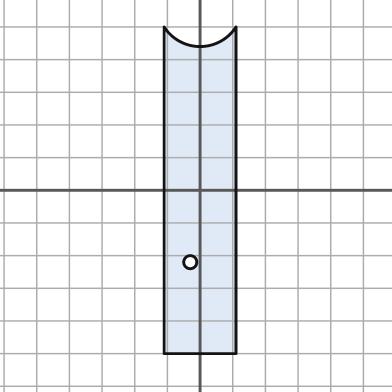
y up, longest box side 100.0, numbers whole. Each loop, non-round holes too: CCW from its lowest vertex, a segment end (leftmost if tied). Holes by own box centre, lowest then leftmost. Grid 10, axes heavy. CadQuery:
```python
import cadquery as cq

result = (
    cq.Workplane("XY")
    .moveTo(-11.0, -50.0)
    .lineTo(11.0, -50.0)
    .lineTo(11.0, 50.0)
    .threePointArc((0.0, 44.0), (-11.0, 50.0))
    .close()
    .moveTo(-3.0, -22.0)
    .circle(2.0)
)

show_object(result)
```